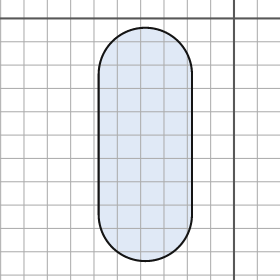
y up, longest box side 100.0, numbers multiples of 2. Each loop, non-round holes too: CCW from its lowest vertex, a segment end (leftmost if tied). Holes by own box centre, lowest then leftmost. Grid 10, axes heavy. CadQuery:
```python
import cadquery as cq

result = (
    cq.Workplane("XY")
    .moveTo(-58.0, -84.0)
    .threePointArc((-38.0, -104.0), (-18.0, -84.0))
    .lineTo(-18.0, -24.0)
    .threePointArc((-38.0, -4.0), (-58.0, -24.0))
    .close()
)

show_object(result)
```